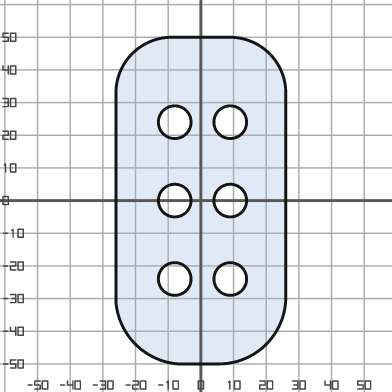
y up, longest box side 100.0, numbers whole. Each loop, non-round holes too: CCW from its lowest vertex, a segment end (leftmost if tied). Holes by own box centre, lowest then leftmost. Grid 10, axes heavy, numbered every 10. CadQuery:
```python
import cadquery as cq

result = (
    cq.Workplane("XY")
    .moveTo(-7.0, -50.0)
    .lineTo(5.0, -50.0)
    .threePointArc((20.0, -44.0), (26.0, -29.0))
    .lineTo(26.0, 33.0)
    .threePointArc((21.0, 45.0), (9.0, 50.0))
    .lineTo(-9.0, 50.0)
    .threePointArc((-21.0, 45.0), (-26.0, 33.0))
    .lineTo(-26.0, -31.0)
    .threePointArc((-20.0, -44.0), (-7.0, -50.0))
    .close()
    .moveTo(-8.0, -24.0)
    .circle(5.0)
    .moveTo(9.0, -24.0)
    .circle(5.0)
    .moveTo(-8.0, 0.0)
    .circle(5.0)
    .moveTo(9.0, 0.0)
    .circle(5.0)
    .moveTo(-8.0, 24.0)
    .circle(5.0)
    .moveTo(9.0, 24.0)
    .circle(5.0)
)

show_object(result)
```